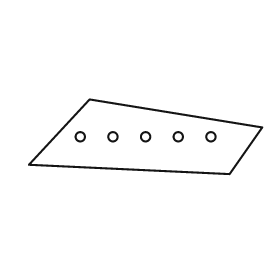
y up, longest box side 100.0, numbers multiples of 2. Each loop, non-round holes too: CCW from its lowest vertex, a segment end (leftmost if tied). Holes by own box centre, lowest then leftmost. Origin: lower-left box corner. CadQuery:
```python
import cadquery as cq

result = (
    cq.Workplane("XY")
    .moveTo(86.0, 0.0)
    .lineTo(100.0, 20.0)
    .lineTo(26.0, 32.0)
    .lineTo(0.0, 4.0)
    .close()
    .moveTo(22.0, 16.0)
    .circle(2.0)
    .moveTo(36.0, 16.0)
    .circle(2.0)
    .moveTo(50.0, 16.0)
    .circle(2.0)
    .moveTo(64.0, 16.0)
    .circle(2.0)
    .moveTo(78.0, 16.0)
    .circle(2.0)
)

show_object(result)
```